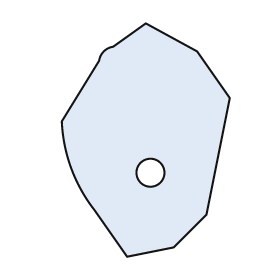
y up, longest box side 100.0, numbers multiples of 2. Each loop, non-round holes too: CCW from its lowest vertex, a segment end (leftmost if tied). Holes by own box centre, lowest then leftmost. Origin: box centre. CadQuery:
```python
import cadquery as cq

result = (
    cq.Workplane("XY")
    .moveTo(-8.0, -50.0)
    .lineTo(12.0, -46.0)
    .lineTo(26.0, -32.0)
    .lineTo(36.0, 18.0)
    .lineTo(22.0, 38.0)
    .lineTo(0.0, 50.0)
    .lineTo(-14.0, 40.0)
    .threePointArc((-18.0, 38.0), (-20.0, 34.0))
    .lineTo(-36.0, 8.0)
    .threePointArc((-32.0, -12.0), (-22.0, -30.0))
    .close()
    .moveTo(2.0, -14.0)
    .circle(6.0)
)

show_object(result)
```